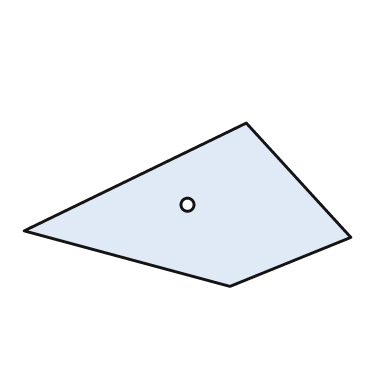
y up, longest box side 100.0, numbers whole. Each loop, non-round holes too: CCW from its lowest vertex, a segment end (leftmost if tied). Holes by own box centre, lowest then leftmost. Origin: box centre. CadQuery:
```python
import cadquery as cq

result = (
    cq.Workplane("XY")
    .moveTo(13.0, -25.0)
    .lineTo(50.0, -10.0)
    .lineTo(18.0, 25.0)
    .lineTo(-50.0, -8.0)
    .close()
    .moveTo(0.0, 0.0)
    .circle(2.0)
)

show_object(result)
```